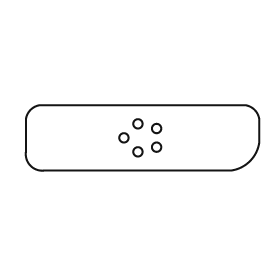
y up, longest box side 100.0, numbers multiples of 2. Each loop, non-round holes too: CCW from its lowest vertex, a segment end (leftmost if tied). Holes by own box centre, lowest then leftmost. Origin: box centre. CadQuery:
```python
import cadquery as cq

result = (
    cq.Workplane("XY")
    .moveTo(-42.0, -14.0)
    .lineTo(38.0, -14.0)
    .threePointArc((46.0, -10.0), (50.0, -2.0))
    .lineTo(50.0, 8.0)
    .threePointArc((48.0, 12.0), (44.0, 14.0))
    .lineTo(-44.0, 14.0)
    .threePointArc((-48.0, 12.0), (-50.0, 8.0))
    .lineTo(-50.0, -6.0)
    .threePointArc((-48.0, -12.0), (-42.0, -14.0))
    .close()
    .moveTo(-2.0, -6.0)
    .circle(2.0)
    .moveTo(6.0, -4.0)
    .circle(2.0)
    .moveTo(-8.0, 0.0)
    .circle(2.0)
    .moveTo(6.0, 4.0)
    .circle(2.0)
    .moveTo(-2.0, 6.0)
    .circle(2.0)
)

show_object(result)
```